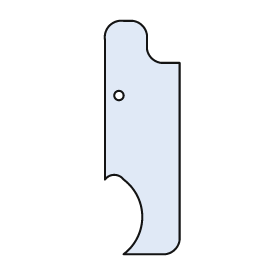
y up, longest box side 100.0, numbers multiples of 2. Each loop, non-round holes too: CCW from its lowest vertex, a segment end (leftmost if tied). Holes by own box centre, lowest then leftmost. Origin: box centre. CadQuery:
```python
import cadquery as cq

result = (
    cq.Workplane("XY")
    .moveTo(-8.0, -50.0)
    .lineTo(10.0, -50.0)
    .threePointArc((14.0, -48.0), (16.0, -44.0))
    .lineTo(16.0, 32.0)
    .lineTo(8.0, 32.0)
    .threePointArc((4.0, 34.0), (2.0, 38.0))
    .lineTo(2.0, 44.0)
    .threePointArc((0.0, 48.0), (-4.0, 50.0))
    .lineTo(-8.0, 50.0)
    .threePointArc((-14.0, 48.0), (-16.0, 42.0))
    .lineTo(-16.0, -18.0)
    .threePointArc((-12.0, -16.0), (-8.0, -18.0))
    .threePointArc((0.0, -34.0), (-8.0, -50.0))
    .close()
    .moveTo(-10.0, 18.0)
    .circle(2.0)
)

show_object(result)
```